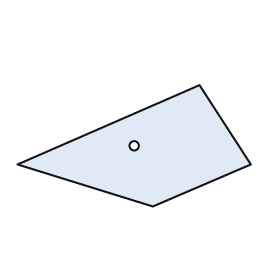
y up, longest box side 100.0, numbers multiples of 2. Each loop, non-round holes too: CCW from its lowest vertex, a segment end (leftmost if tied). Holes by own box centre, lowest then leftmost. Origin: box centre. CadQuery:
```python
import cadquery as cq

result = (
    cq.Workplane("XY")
    .moveTo(8.0, -26.0)
    .lineTo(50.0, -8.0)
    .lineTo(28.0, 26.0)
    .lineTo(-50.0, -8.0)
    .close()
    .moveTo(0.0, 0.0)
    .circle(2.0)
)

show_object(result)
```